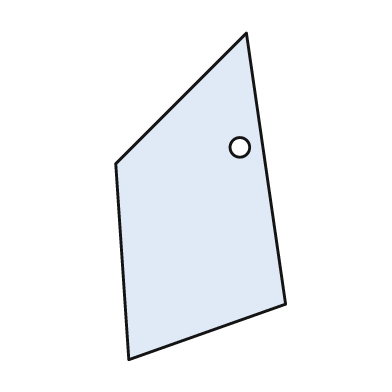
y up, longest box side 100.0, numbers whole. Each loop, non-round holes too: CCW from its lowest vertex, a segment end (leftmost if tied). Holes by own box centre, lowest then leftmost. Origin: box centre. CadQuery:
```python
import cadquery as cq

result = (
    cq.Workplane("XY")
    .moveTo(-22.0, -50.0)
    .lineTo(26.0, -33.0)
    .lineTo(14.0, 50.0)
    .lineTo(-26.0, 10.0)
    .close()
    .moveTo(12.0, 15.0)
    .circle(3.0)
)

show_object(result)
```